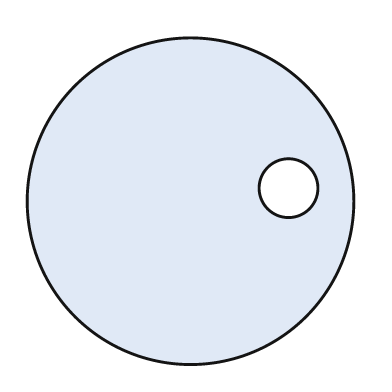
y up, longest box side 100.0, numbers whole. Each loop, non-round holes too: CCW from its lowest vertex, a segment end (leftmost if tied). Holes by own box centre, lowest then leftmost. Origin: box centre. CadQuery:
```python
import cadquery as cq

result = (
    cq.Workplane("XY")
    .moveTo(0.0, 0.0)
    .circle(50.0)
    .moveTo(30.0, 4.0)
    .circle(9.0)
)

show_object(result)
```